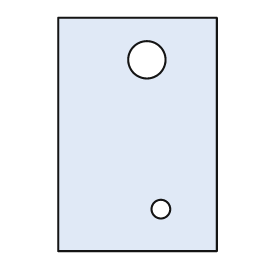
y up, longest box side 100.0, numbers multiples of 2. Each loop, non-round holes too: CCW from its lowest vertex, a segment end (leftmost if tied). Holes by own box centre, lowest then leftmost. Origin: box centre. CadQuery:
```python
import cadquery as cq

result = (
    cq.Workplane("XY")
    .moveTo(-34.0, -50.0)
    .lineTo(34.0, -50.0)
    .lineTo(34.0, 50.0)
    .lineTo(-34.0, 50.0)
    .close()
    .moveTo(10.0, -32.0)
    .circle(4.0)
    .moveTo(4.0, 32.0)
    .circle(8.0)
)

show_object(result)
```